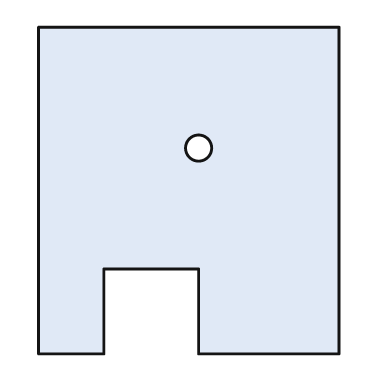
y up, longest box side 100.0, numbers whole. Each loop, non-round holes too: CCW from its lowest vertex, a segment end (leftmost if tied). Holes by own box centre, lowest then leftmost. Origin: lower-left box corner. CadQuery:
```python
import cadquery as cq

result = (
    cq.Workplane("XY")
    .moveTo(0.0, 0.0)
    .lineTo(20.0, 0.0)
    .lineTo(20.0, 26.0)
    .lineTo(49.0, 26.0)
    .lineTo(49.0, 0.0)
    .lineTo(92.0, 0.0)
    .lineTo(92.0, 100.0)
    .lineTo(0.0, 100.0)
    .close()
    .moveTo(49.0, 63.0)
    .circle(4.0)
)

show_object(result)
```